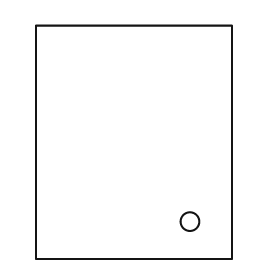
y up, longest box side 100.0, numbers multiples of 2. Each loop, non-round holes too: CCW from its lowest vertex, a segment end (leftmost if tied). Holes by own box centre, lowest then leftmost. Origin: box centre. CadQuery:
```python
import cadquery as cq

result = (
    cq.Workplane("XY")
    .moveTo(-42.0, -50.0)
    .lineTo(42.0, -50.0)
    .lineTo(42.0, 50.0)
    .lineTo(-42.0, 50.0)
    .close()
    .moveTo(24.0, -34.0)
    .circle(4.0)
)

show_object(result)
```